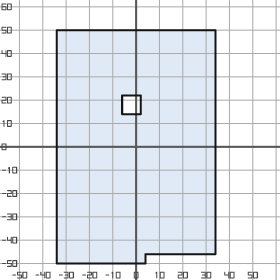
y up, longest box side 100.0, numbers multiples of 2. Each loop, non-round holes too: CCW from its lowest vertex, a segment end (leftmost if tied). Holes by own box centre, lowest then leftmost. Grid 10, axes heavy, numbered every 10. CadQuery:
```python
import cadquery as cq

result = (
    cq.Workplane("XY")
    .moveTo(-34.0, -50.0)
    .lineTo(4.0, -50.0)
    .lineTo(4.0, -46.0)
    .lineTo(34.0, -46.0)
    .lineTo(34.0, 50.0)
    .lineTo(-34.0, 50.0)
    .close()
    .moveTo(-6.0, 14.0)
    .lineTo(2.0, 14.0)
    .lineTo(2.0, 22.0)
    .lineTo(-6.0, 22.0)
    .close()
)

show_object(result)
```